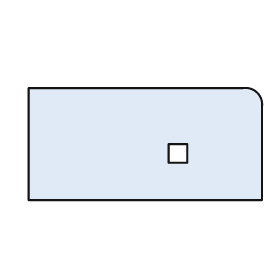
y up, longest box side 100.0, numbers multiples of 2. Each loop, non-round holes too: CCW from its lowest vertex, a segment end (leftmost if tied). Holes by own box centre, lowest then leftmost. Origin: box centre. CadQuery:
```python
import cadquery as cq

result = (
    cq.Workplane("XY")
    .moveTo(-50.0, -24.0)
    .lineTo(50.0, -24.0)
    .lineTo(50.0, 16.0)
    .threePointArc((48.0, 22.0), (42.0, 24.0))
    .lineTo(-50.0, 24.0)
    .close()
    .moveTo(10.0, -8.0)
    .lineTo(18.0, -8.0)
    .lineTo(18.0, 0.0)
    .lineTo(10.0, 0.0)
    .close()
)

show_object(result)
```